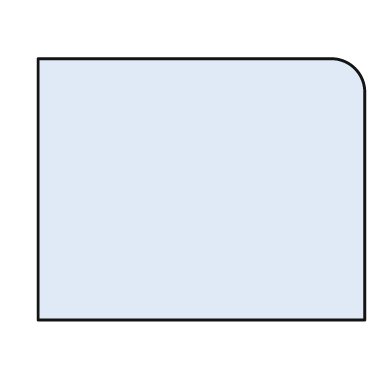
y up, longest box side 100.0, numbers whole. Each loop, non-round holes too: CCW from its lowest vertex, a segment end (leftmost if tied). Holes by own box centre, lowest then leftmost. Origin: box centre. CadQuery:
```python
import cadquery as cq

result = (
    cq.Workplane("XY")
    .moveTo(-50.0, -40.0)
    .lineTo(50.0, -40.0)
    .lineTo(50.0, 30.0)
    .threePointArc((47.0, 37.0), (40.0, 40.0))
    .lineTo(-50.0, 40.0)
    .close()
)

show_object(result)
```